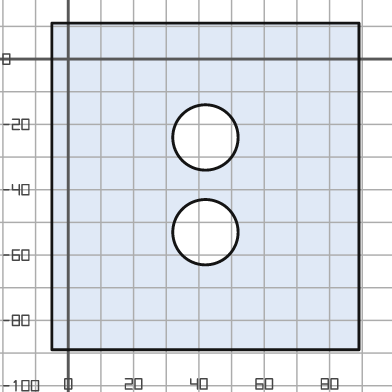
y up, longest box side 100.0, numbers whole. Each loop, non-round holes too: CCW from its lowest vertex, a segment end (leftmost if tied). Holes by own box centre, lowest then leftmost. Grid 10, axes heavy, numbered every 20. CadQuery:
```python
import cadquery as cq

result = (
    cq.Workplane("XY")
    .moveTo(-5.0, -89.0)
    .lineTo(89.0, -89.0)
    .lineTo(89.0, 11.0)
    .lineTo(-5.0, 11.0)
    .close()
    .moveTo(42.0, -53.0)
    .circle(10.0)
    .moveTo(42.0, -24.0)
    .circle(10.0)
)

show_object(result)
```